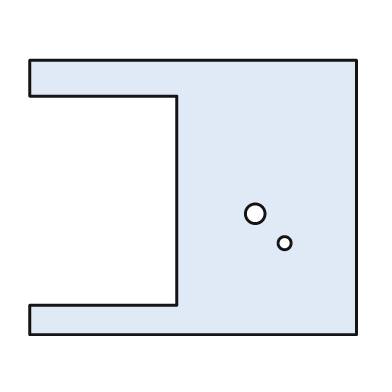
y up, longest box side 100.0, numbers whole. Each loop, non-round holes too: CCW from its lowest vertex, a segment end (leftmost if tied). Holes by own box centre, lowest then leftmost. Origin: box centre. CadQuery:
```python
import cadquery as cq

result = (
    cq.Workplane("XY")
    .moveTo(-50.0, -42.0)
    .lineTo(50.0, -42.0)
    .lineTo(50.0, 42.0)
    .lineTo(-50.0, 42.0)
    .lineTo(-50.0, 31.0)
    .lineTo(-5.0, 31.0)
    .lineTo(-5.0, -33.0)
    .lineTo(-50.0, -33.0)
    .close()
    .moveTo(28.0, -14.0)
    .circle(2.0)
    .moveTo(19.0, -5.0)
    .circle(3.0)
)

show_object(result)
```